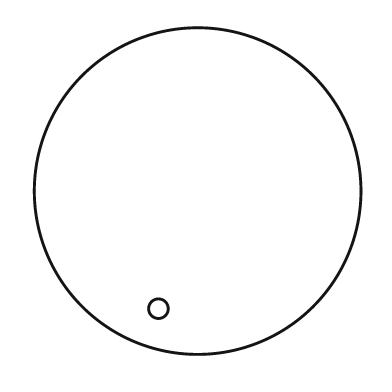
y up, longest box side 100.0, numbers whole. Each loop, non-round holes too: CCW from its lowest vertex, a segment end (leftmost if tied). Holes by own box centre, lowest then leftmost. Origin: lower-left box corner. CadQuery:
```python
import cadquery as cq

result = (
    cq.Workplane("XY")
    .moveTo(50.0, 50.0)
    .circle(50.0)
    .moveTo(38.0, 14.0)
    .circle(3.0)
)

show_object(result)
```